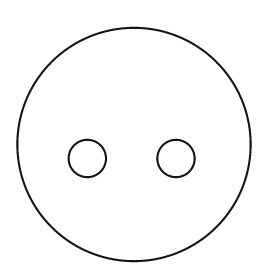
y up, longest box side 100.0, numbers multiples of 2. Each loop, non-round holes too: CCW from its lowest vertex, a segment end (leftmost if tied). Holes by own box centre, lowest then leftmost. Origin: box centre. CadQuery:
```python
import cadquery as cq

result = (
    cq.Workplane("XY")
    .moveTo(0.0, 0.0)
    .circle(50.0)
    .moveTo(-20.0, -6.0)
    .circle(8.0)
    .moveTo(18.0, -6.0)
    .circle(8.0)
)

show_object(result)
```